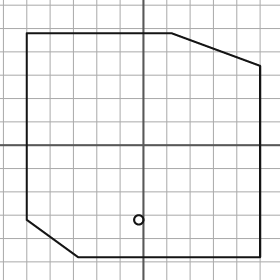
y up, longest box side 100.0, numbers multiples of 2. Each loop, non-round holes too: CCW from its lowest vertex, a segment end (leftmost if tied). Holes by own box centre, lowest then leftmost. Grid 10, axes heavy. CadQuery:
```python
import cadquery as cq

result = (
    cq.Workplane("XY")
    .moveTo(-28.0, -48.0)
    .lineTo(50.0, -48.0)
    .lineTo(50.0, 34.0)
    .lineTo(12.0, 48.0)
    .lineTo(-50.0, 48.0)
    .lineTo(-50.0, -32.0)
    .close()
    .moveTo(-2.0, -32.0)
    .circle(2.0)
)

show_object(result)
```